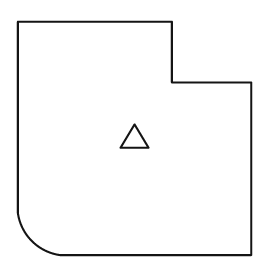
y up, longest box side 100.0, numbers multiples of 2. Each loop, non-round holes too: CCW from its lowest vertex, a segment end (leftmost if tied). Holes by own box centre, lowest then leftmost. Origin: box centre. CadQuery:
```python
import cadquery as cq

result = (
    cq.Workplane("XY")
    .moveTo(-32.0, -50.0)
    .lineTo(50.0, -50.0)
    .lineTo(50.0, 24.0)
    .lineTo(16.0, 24.0)
    .lineTo(16.0, 50.0)
    .lineTo(-50.0, 50.0)
    .lineTo(-50.0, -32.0)
    .threePointArc((-44.0, -44.0), (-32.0, -50.0))
    .close()
    .moveTo(-6.0, -4.0)
    .lineTo(6.0, -4.0)
    .lineTo(0.0, 6.0)
    .close()
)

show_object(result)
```